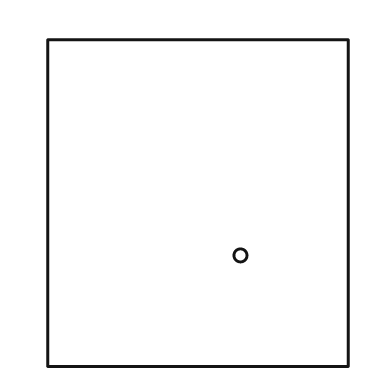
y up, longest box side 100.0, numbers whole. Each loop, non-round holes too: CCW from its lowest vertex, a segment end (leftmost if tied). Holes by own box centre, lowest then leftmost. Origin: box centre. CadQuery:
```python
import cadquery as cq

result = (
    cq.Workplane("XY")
    .moveTo(-46.0, -50.0)
    .lineTo(46.0, -50.0)
    .lineTo(46.0, 50.0)
    .lineTo(-46.0, 50.0)
    .close()
    .moveTo(13.0, -16.0)
    .circle(2.0)
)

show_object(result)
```